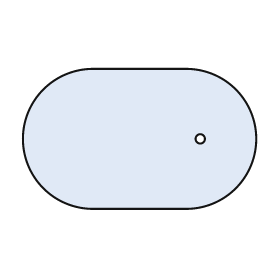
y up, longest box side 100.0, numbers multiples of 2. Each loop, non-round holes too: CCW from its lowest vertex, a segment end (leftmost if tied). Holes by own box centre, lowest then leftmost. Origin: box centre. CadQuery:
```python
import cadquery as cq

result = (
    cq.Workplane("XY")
    .moveTo(-20.0, -30.0)
    .lineTo(20.0, -30.0)
    .threePointArc((50.0, 0.0), (20.0, 30.0))
    .lineTo(-20.0, 30.0)
    .threePointArc((-50.0, 0.0), (-20.0, -30.0))
    .close()
    .moveTo(26.0, 0.0)
    .circle(2.0)
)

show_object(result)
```